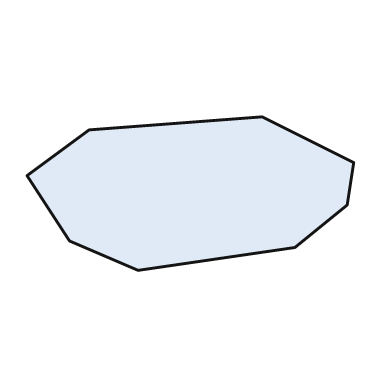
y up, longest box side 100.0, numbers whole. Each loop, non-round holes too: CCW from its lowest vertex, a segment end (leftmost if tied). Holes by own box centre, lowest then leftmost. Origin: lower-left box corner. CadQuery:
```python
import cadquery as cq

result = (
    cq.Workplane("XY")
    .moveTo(34.0, 0.0)
    .lineTo(82.0, 7.0)
    .lineTo(98.0, 20.0)
    .lineTo(100.0, 33.0)
    .lineTo(72.0, 47.0)
    .lineTo(19.0, 43.0)
    .lineTo(0.0, 29.0)
    .lineTo(13.0, 9.0)
    .close()
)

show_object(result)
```